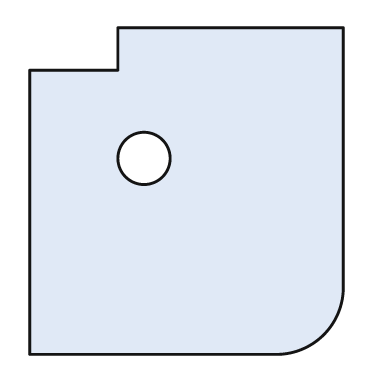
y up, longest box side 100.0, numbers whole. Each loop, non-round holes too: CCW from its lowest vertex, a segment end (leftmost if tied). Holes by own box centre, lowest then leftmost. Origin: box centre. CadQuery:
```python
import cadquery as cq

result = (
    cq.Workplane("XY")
    .moveTo(-48.0, -50.0)
    .lineTo(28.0, -50.0)
    .threePointArc((42.0, -44.0), (48.0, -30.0))
    .lineTo(48.0, 50.0)
    .lineTo(-21.0, 50.0)
    .lineTo(-21.0, 37.0)
    .lineTo(-48.0, 37.0)
    .close()
    .moveTo(-13.0, 10.0)
    .circle(8.0)
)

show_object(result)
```